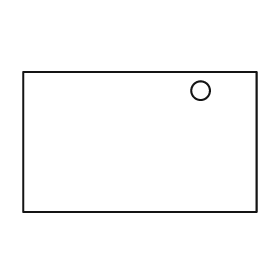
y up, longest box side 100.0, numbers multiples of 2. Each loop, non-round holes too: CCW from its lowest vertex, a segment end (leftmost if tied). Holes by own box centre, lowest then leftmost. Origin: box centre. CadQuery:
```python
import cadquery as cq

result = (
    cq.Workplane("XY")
    .moveTo(-50.0, -30.0)
    .lineTo(50.0, -30.0)
    .lineTo(50.0, 30.0)
    .lineTo(-50.0, 30.0)
    .close()
    .moveTo(26.0, 22.0)
    .circle(4.0)
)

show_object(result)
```